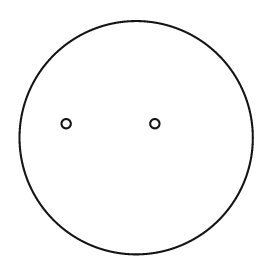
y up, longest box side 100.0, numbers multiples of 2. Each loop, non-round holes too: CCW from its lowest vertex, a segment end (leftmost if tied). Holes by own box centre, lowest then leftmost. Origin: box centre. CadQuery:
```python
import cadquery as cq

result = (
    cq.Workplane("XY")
    .moveTo(0.0, 0.0)
    .circle(50.0)
    .moveTo(-30.0, 6.0)
    .circle(2.0)
    .moveTo(8.0, 6.0)
    .circle(2.0)
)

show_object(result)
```